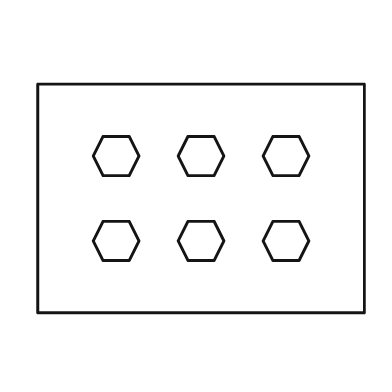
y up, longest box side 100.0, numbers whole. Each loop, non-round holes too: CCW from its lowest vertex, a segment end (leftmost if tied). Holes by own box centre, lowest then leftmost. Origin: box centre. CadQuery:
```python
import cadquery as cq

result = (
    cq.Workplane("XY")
    .moveTo(-50.0, -35.0)
    .lineTo(50.0, -35.0)
    .lineTo(50.0, 35.0)
    .lineTo(-50.0, 35.0)
    .close()
    .moveTo(-30.0, -19.0)
    .lineTo(-22.0, -19.0)
    .lineTo(-19.0, -13.0)
    .lineTo(-22.0, -7.0)
    .lineTo(-30.0, -7.0)
    .lineTo(-33.0, -13.0)
    .close()
    .moveTo(-4.0, -19.0)
    .lineTo(4.0, -19.0)
    .lineTo(7.0, -13.0)
    .lineTo(4.0, -7.0)
    .lineTo(-4.0, -7.0)
    .lineTo(-7.0, -13.0)
    .close()
    .moveTo(22.0, -19.0)
    .lineTo(30.0, -19.0)
    .lineTo(33.0, -13.0)
    .lineTo(30.0, -7.0)
    .lineTo(22.0, -7.0)
    .lineTo(19.0, -13.0)
    .close()
    .moveTo(-30.0, 7.0)
    .lineTo(-22.0, 7.0)
    .lineTo(-19.0, 13.0)
    .lineTo(-22.0, 19.0)
    .lineTo(-30.0, 19.0)
    .lineTo(-33.0, 13.0)
    .close()
    .moveTo(-4.0, 7.0)
    .lineTo(4.0, 7.0)
    .lineTo(7.0, 13.0)
    .lineTo(4.0, 19.0)
    .lineTo(-4.0, 19.0)
    .lineTo(-7.0, 13.0)
    .close()
    .moveTo(22.0, 7.0)
    .lineTo(30.0, 7.0)
    .lineTo(33.0, 13.0)
    .lineTo(30.0, 19.0)
    .lineTo(22.0, 19.0)
    .lineTo(19.0, 13.0)
    .close()
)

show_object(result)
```